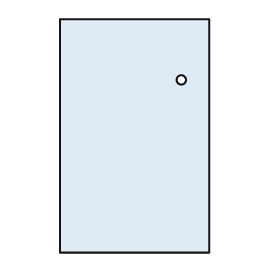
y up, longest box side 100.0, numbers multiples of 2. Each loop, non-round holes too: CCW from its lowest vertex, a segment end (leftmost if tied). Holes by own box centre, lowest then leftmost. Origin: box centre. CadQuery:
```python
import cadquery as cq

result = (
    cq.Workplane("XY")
    .moveTo(-32.0, -50.0)
    .lineTo(32.0, -50.0)
    .lineTo(32.0, 50.0)
    .lineTo(-32.0, 50.0)
    .close()
    .moveTo(20.0, 24.0)
    .circle(2.0)
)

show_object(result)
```